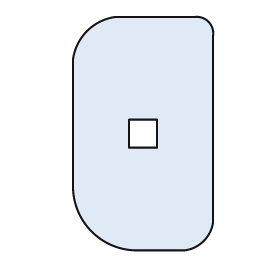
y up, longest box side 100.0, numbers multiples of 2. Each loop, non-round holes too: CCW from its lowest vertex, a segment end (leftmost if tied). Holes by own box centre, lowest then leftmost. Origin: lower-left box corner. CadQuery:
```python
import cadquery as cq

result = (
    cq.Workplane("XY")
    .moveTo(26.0, 0.0)
    .lineTo(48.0, 0.0)
    .threePointArc((56.0, 4.0), (60.0, 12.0))
    .lineTo(60.0, 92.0)
    .threePointArc((58.0, 98.0), (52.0, 100.0))
    .lineTo(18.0, 100.0)
    .threePointArc((6.0, 94.0), (0.0, 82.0))
    .lineTo(0.0, 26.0)
    .threePointArc((8.0, 8.0), (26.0, 0.0))
    .close()
    .moveTo(24.0, 44.0)
    .lineTo(36.0, 44.0)
    .lineTo(36.0, 56.0)
    .lineTo(24.0, 56.0)
    .close()
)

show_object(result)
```